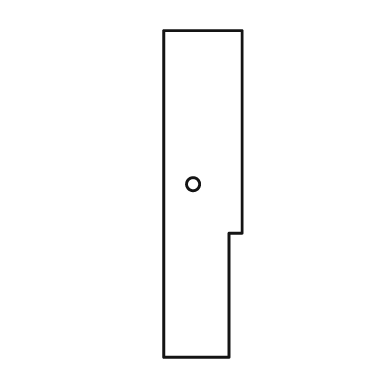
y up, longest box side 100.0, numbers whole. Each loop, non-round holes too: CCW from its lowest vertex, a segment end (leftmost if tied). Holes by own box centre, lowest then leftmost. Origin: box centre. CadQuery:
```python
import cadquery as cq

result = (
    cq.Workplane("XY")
    .moveTo(-12.0, -50.0)
    .lineTo(8.0, -50.0)
    .lineTo(8.0, -12.0)
    .lineTo(12.0, -12.0)
    .lineTo(12.0, 50.0)
    .lineTo(-12.0, 50.0)
    .close()
    .moveTo(-3.0, 3.0)
    .circle(2.0)
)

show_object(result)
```